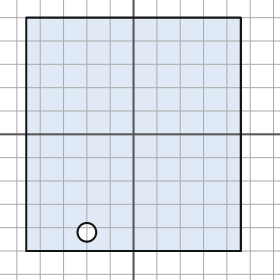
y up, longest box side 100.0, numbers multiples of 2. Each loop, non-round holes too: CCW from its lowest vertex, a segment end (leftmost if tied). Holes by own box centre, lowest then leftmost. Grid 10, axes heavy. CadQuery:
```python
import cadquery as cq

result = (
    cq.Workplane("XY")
    .moveTo(-46.0, -50.0)
    .lineTo(46.0, -50.0)
    .lineTo(46.0, 50.0)
    .lineTo(-46.0, 50.0)
    .close()
    .moveTo(-20.0, -42.0)
    .circle(4.0)
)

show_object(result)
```